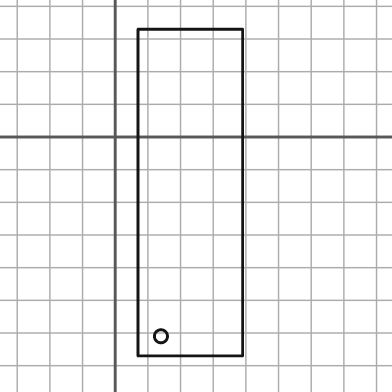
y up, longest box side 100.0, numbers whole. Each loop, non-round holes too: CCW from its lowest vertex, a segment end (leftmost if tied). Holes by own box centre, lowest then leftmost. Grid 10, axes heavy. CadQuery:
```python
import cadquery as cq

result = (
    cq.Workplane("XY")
    .moveTo(7.0, -67.0)
    .lineTo(39.0, -67.0)
    .lineTo(39.0, 33.0)
    .lineTo(7.0, 33.0)
    .close()
    .moveTo(14.0, -61.0)
    .circle(2.0)
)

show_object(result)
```